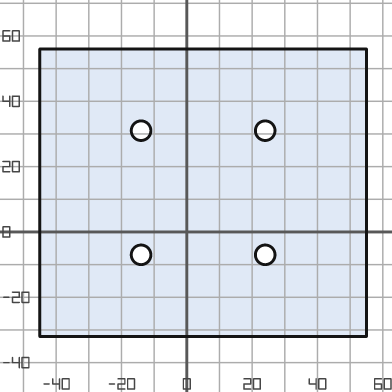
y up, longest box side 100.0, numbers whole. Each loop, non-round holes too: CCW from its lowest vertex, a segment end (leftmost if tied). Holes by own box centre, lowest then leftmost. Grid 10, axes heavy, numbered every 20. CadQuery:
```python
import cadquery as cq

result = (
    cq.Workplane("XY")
    .moveTo(-45.0, -32.0)
    .lineTo(55.0, -32.0)
    .lineTo(55.0, 56.0)
    .lineTo(-45.0, 56.0)
    .close()
    .moveTo(-14.0, -7.0)
    .circle(3.0)
    .moveTo(24.0, -7.0)
    .circle(3.0)
    .moveTo(-14.0, 31.0)
    .circle(3.0)
    .moveTo(24.0, 31.0)
    .circle(3.0)
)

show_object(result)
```